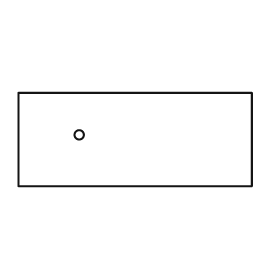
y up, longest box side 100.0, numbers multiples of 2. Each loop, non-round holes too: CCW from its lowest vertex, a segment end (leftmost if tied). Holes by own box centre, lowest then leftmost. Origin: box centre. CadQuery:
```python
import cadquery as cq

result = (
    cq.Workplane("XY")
    .moveTo(-50.0, -20.0)
    .lineTo(50.0, -20.0)
    .lineTo(50.0, 20.0)
    .lineTo(-50.0, 20.0)
    .close()
    .moveTo(-24.0, 2.0)
    .circle(2.0)
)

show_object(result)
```